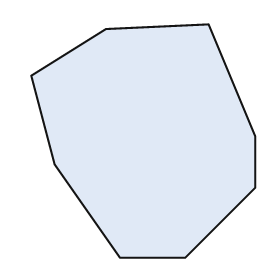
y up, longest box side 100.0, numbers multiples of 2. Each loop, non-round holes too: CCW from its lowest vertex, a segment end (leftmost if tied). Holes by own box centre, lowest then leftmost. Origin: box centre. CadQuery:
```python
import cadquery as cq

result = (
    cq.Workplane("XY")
    .moveTo(-10.0, -50.0)
    .lineTo(18.0, -50.0)
    .lineTo(48.0, -20.0)
    .lineTo(48.0, 2.0)
    .lineTo(28.0, 50.0)
    .lineTo(-16.0, 48.0)
    .lineTo(-48.0, 28.0)
    .lineTo(-38.0, -10.0)
    .close()
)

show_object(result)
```